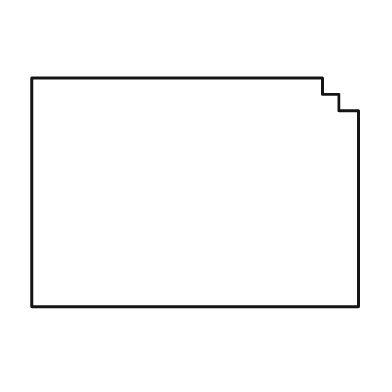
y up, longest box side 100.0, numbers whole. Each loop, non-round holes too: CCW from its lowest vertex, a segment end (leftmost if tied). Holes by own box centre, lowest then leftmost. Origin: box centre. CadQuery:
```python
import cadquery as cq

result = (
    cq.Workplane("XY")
    .moveTo(-50.0, -35.0)
    .lineTo(50.0, -35.0)
    .lineTo(50.0, 25.0)
    .lineTo(44.0, 25.0)
    .lineTo(44.0, 30.0)
    .lineTo(39.0, 30.0)
    .lineTo(39.0, 35.0)
    .lineTo(-50.0, 35.0)
    .close()
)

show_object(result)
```